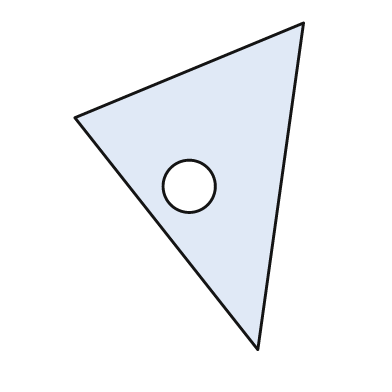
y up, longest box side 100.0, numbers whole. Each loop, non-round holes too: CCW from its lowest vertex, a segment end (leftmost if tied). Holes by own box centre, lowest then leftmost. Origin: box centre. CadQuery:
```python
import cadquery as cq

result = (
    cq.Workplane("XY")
    .moveTo(21.0, -50.0)
    .lineTo(35.0, 50.0)
    .lineTo(-35.0, 21.0)
    .close()
    .moveTo(0.0, 0.0)
    .circle(8.0)
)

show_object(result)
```